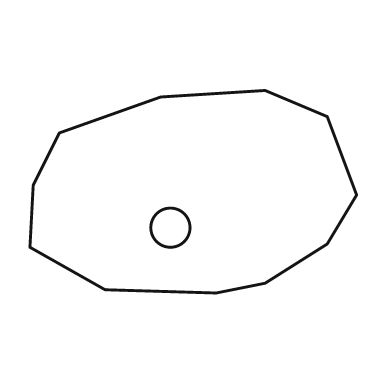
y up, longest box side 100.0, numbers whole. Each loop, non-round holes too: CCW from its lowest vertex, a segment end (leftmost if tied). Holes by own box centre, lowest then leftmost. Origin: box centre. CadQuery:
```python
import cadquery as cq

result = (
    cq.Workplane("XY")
    .moveTo(7.0, -31.0)
    .lineTo(22.0, -28.0)
    .lineTo(41.0, -16.0)
    .lineTo(50.0, -1.0)
    .lineTo(41.0, 23.0)
    .lineTo(22.0, 31.0)
    .lineTo(-10.0, 29.0)
    .lineTo(-41.0, 18.0)
    .lineTo(-49.0, 2.0)
    .lineTo(-50.0, -17.0)
    .lineTo(-27.0, -30.0)
    .close()
    .moveTo(-7.0, -11.0)
    .circle(6.0)
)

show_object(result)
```